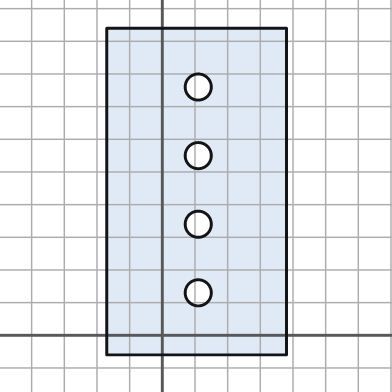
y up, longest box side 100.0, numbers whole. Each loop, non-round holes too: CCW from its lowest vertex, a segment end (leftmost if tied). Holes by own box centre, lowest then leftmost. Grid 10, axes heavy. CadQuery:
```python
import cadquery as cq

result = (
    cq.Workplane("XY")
    .moveTo(-17.0, -6.0)
    .lineTo(38.0, -6.0)
    .lineTo(38.0, 94.0)
    .lineTo(-17.0, 94.0)
    .close()
    .moveTo(11.0, 13.0)
    .circle(4.0)
    .moveTo(11.0, 34.0)
    .circle(4.0)
    .moveTo(11.0, 55.0)
    .circle(4.0)
    .moveTo(11.0, 76.0)
    .circle(4.0)
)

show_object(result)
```